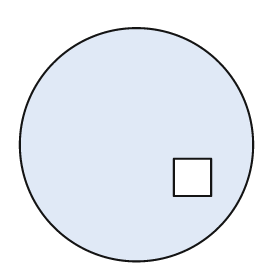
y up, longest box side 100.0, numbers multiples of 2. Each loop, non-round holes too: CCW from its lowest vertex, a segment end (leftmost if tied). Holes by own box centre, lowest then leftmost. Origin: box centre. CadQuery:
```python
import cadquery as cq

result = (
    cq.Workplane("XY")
    .moveTo(0.0, 0.0)
    .circle(50.0)
    .moveTo(16.0, -22.0)
    .lineTo(32.0, -22.0)
    .lineTo(32.0, -6.0)
    .lineTo(16.0, -6.0)
    .close()
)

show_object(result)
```